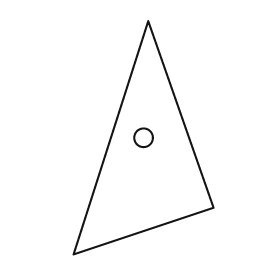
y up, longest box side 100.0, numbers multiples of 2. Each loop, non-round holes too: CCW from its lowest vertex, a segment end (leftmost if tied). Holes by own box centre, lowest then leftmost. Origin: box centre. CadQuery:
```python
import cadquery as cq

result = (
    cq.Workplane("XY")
    .moveTo(-30.0, -50.0)
    .lineTo(30.0, -30.0)
    .lineTo(2.0, 50.0)
    .close()
    .moveTo(0.0, 0.0)
    .circle(4.0)
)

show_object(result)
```